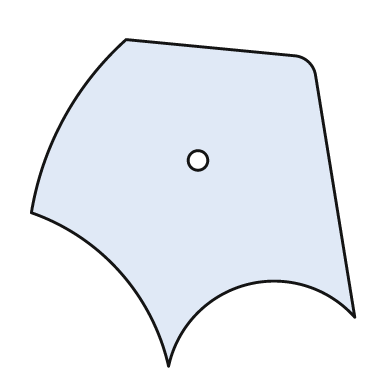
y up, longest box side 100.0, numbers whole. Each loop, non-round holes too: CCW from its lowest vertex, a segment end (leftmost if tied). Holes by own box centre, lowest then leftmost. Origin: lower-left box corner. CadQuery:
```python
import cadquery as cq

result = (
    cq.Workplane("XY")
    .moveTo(42.0, 0.0)
    .threePointArc((66.0, 25.0), (99.0, 15.0))
    .lineTo(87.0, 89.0)
    .threePointArc((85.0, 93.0), (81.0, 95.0))
    .lineTo(29.0, 100.0)
    .threePointArc((10.0, 76.0), (0.0, 47.0))
    .threePointArc((27.0, 29.0), (42.0, 0.0))
    .close()
    .moveTo(51.0, 63.0)
    .circle(3.0)
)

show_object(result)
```